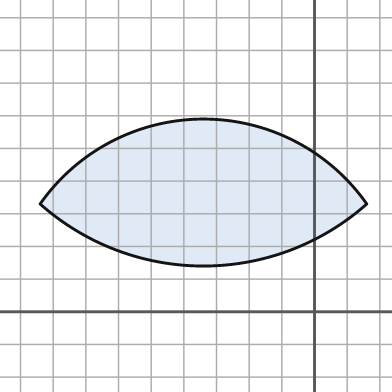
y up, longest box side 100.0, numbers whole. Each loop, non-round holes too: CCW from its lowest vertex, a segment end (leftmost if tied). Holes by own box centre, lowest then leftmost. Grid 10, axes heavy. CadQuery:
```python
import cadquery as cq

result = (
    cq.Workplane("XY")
    .moveTo(-84.0, 33.0)
    .threePointArc((-34.0, 14.0), (16.0, 33.0))
    .threePointArc((-34.0, 59.0), (-84.0, 33.0))
    .close()
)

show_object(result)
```